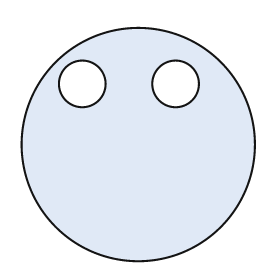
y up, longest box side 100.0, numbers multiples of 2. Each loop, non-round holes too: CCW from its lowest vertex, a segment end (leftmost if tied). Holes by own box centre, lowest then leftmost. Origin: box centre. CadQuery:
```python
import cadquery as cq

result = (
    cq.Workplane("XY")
    .moveTo(0.0, 0.0)
    .circle(50.0)
    .moveTo(-24.0, 26.0)
    .circle(10.0)
    .moveTo(16.0, 26.0)
    .circle(10.0)
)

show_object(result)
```